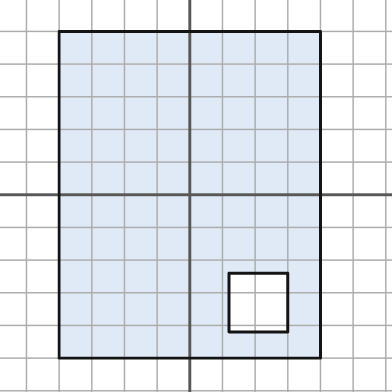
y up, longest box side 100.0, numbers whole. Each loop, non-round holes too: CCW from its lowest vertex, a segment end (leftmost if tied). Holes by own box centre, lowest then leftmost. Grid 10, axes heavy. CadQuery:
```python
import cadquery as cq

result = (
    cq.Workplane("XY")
    .moveTo(-40.0, -50.0)
    .lineTo(40.0, -50.0)
    .lineTo(40.0, 50.0)
    .lineTo(-40.0, 50.0)
    .close()
    .moveTo(12.0, -42.0)
    .lineTo(30.0, -42.0)
    .lineTo(30.0, -24.0)
    .lineTo(12.0, -24.0)
    .close()
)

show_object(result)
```